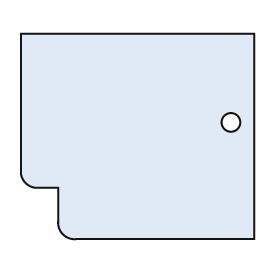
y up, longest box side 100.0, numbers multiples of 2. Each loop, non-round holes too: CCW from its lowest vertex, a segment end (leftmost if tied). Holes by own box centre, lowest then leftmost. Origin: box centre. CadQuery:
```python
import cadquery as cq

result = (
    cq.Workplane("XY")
    .moveTo(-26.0, -44.0)
    .lineTo(50.0, -44.0)
    .lineTo(50.0, 44.0)
    .lineTo(-50.0, 44.0)
    .lineTo(-50.0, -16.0)
    .threePointArc((-48.0, -20.0), (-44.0, -22.0))
    .lineTo(-34.0, -22.0)
    .lineTo(-34.0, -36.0)
    .threePointArc((-32.0, -42.0), (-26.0, -44.0))
    .close()
    .moveTo(40.0, 6.0)
    .circle(4.0)
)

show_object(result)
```